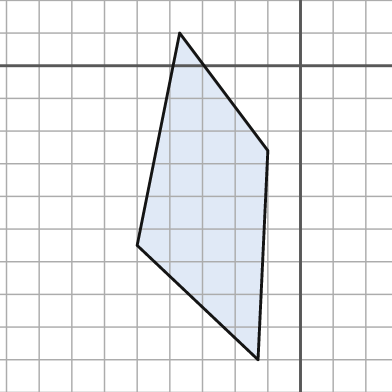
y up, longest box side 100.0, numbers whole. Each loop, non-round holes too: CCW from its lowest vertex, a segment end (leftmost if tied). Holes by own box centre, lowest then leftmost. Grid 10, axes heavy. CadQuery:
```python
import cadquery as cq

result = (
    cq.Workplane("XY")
    .moveTo(-13.0, -90.0)
    .lineTo(-10.0, -26.0)
    .lineTo(-37.0, 10.0)
    .lineTo(-50.0, -55.0)
    .close()
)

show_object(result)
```